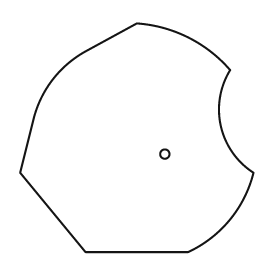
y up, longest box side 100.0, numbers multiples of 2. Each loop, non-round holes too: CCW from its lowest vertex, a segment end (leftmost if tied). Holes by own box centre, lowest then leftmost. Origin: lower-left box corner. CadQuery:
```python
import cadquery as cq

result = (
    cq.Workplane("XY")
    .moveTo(28.0, 0.0)
    .lineTo(72.0, 0.0)
    .threePointArc((90.0, 14.0), (100.0, 34.0))
    .threePointArc((86.0, 54.0), (90.0, 78.0))
    .threePointArc((72.0, 92.0), (50.0, 98.0))
    .lineTo(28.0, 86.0)
    .threePointArc((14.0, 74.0), (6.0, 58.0))
    .lineTo(0.0, 34.0)
    .close()
    .moveTo(62.0, 42.0)
    .circle(2.0)
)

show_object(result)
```